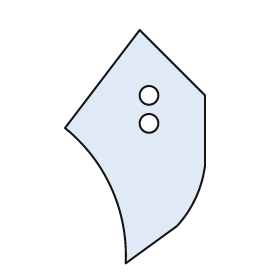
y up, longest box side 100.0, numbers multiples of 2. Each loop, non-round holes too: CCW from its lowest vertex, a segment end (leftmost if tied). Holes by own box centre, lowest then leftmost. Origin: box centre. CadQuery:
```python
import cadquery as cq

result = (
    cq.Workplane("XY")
    .moveTo(-4.0, -50.0)
    .lineTo(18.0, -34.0)
    .threePointArc((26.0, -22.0), (30.0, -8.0))
    .lineTo(30.0, 22.0)
    .lineTo(2.0, 50.0)
    .lineTo(-30.0, 8.0)
    .threePointArc((-10.0, -18.0), (-4.0, -50.0))
    .close()
    .moveTo(6.0, 10.0)
    .circle(4.0)
    .moveTo(6.0, 22.0)
    .circle(4.0)
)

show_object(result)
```